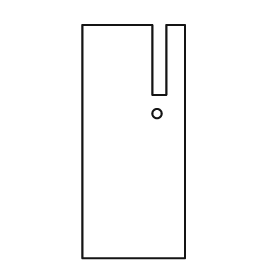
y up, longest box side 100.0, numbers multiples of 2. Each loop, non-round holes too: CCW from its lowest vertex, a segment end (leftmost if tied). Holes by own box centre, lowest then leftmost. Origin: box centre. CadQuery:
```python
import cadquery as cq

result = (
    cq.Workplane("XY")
    .moveTo(-22.0, -50.0)
    .lineTo(22.0, -50.0)
    .lineTo(22.0, 50.0)
    .lineTo(14.0, 50.0)
    .lineTo(14.0, 20.0)
    .lineTo(8.0, 20.0)
    .lineTo(8.0, 50.0)
    .lineTo(-22.0, 50.0)
    .close()
    .moveTo(10.0, 12.0)
    .circle(2.0)
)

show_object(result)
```